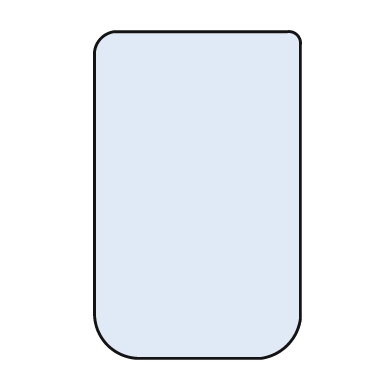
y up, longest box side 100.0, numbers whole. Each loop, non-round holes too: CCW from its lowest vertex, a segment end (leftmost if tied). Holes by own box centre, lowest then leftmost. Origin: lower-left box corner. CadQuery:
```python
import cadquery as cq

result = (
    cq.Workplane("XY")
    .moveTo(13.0, 0.0)
    .lineTo(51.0, 0.0)
    .threePointArc((59.0, 4.0), (63.0, 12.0))
    .lineTo(63.0, 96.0)
    .threePointArc((62.0, 99.0), (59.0, 100.0))
    .lineTo(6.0, 100.0)
    .threePointArc((2.0, 98.0), (0.0, 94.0))
    .lineTo(0.0, 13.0)
    .threePointArc((4.0, 4.0), (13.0, 0.0))
    .close()
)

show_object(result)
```